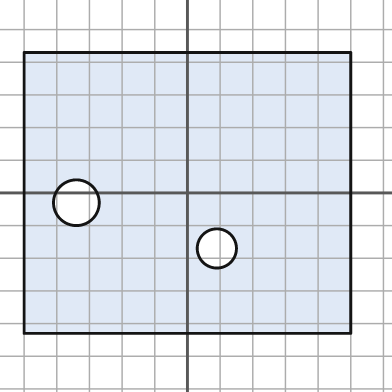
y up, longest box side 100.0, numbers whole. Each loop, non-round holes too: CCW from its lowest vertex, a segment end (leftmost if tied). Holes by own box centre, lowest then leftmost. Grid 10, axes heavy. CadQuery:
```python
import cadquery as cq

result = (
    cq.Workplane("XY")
    .moveTo(-50.0, -43.0)
    .lineTo(50.0, -43.0)
    .lineTo(50.0, 43.0)
    .lineTo(-50.0, 43.0)
    .close()
    .moveTo(9.0, -17.0)
    .circle(6.0)
    .moveTo(-34.0, -3.0)
    .circle(7.0)
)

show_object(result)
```